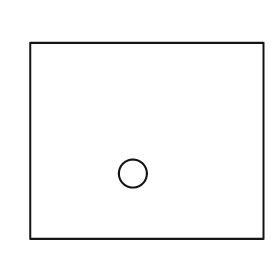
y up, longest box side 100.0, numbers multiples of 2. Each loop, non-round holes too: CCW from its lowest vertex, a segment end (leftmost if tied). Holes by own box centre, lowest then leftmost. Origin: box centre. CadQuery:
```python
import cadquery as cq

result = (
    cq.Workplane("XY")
    .moveTo(-50.0, -42.0)
    .lineTo(50.0, -42.0)
    .lineTo(50.0, 42.0)
    .lineTo(-50.0, 42.0)
    .close()
    .moveTo(-6.0, -14.0)
    .circle(6.0)
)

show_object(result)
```